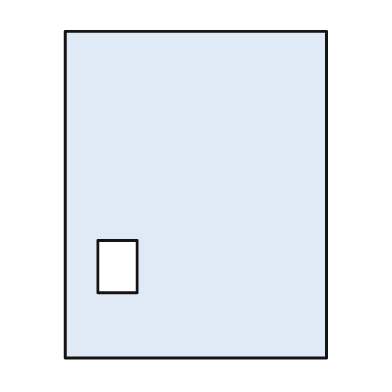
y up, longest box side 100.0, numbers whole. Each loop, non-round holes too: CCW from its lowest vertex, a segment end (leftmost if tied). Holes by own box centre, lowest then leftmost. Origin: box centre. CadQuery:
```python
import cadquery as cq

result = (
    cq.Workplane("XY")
    .moveTo(-40.0, -50.0)
    .lineTo(40.0, -50.0)
    .lineTo(40.0, 50.0)
    .lineTo(-40.0, 50.0)
    .close()
    .moveTo(-30.0, -30.0)
    .lineTo(-18.0, -30.0)
    .lineTo(-18.0, -14.0)
    .lineTo(-30.0, -14.0)
    .close()
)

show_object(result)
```